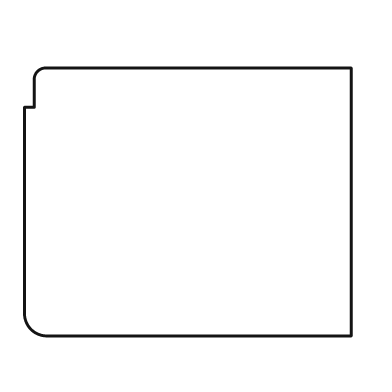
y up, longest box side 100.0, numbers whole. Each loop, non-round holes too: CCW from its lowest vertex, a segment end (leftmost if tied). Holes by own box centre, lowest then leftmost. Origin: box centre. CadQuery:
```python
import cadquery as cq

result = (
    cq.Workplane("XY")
    .moveTo(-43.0, -41.0)
    .lineTo(50.0, -41.0)
    .lineTo(50.0, 41.0)
    .lineTo(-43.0, 41.0)
    .threePointArc((-46.0, 40.0), (-47.0, 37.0))
    .lineTo(-47.0, 29.0)
    .lineTo(-50.0, 29.0)
    .lineTo(-50.0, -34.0)
    .threePointArc((-48.0, -39.0), (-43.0, -41.0))
    .close()
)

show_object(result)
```